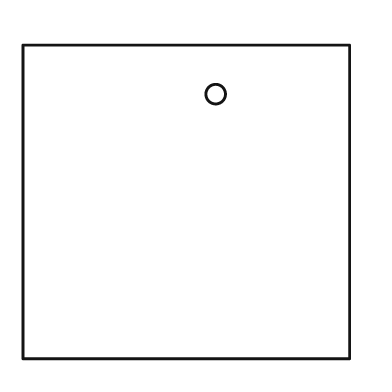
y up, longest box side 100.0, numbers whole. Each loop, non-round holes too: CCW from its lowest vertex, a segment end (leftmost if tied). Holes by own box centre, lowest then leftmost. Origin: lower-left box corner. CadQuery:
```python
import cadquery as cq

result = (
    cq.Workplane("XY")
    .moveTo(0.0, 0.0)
    .lineTo(100.0, 0.0)
    .lineTo(100.0, 96.0)
    .lineTo(0.0, 96.0)
    .close()
    .moveTo(59.0, 81.0)
    .circle(3.0)
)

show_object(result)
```